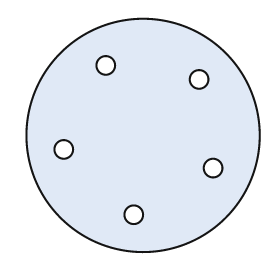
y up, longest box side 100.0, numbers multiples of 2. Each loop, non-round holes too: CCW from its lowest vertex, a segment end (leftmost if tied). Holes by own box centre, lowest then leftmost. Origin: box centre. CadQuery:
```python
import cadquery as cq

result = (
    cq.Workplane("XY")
    .moveTo(0.0, 0.0)
    .circle(50.0)
    .moveTo(-4.0, -34.0)
    .circle(4.0)
    .moveTo(30.0, -14.0)
    .circle(4.0)
    .moveTo(-34.0, -6.0)
    .circle(4.0)
    .moveTo(24.0, 24.0)
    .circle(4.0)
    .moveTo(-16.0, 30.0)
    .circle(4.0)
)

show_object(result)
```